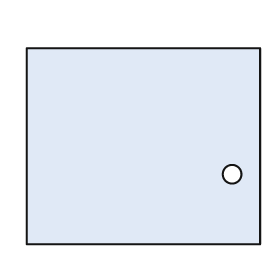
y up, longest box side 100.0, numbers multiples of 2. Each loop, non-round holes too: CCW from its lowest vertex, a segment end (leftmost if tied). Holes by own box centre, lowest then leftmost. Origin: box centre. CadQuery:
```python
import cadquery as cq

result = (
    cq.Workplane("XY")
    .moveTo(-50.0, -42.0)
    .lineTo(50.0, -42.0)
    .lineTo(50.0, 42.0)
    .lineTo(-50.0, 42.0)
    .close()
    .moveTo(38.0, -12.0)
    .circle(4.0)
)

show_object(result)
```